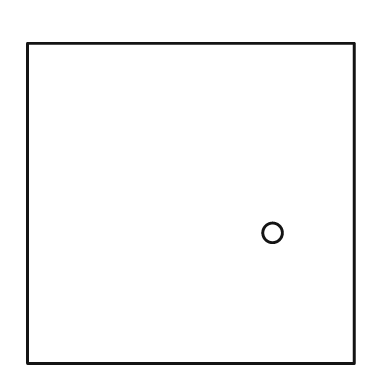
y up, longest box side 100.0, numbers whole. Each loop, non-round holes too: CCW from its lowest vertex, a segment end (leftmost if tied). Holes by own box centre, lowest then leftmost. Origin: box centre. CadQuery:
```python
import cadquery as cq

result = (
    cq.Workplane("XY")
    .moveTo(-50.0, -49.0)
    .lineTo(50.0, -49.0)
    .lineTo(50.0, 49.0)
    .lineTo(-50.0, 49.0)
    .close()
    .moveTo(25.0, -9.0)
    .circle(3.0)
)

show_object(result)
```